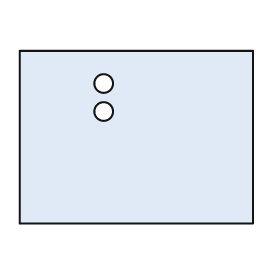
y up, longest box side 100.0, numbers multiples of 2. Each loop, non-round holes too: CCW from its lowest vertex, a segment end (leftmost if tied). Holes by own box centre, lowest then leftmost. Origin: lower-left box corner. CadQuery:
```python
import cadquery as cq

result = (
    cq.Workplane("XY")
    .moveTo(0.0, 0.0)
    .lineTo(100.0, 0.0)
    .lineTo(100.0, 74.0)
    .lineTo(0.0, 74.0)
    .close()
    .moveTo(36.0, 48.0)
    .circle(4.0)
    .moveTo(36.0, 60.0)
    .circle(4.0)
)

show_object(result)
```